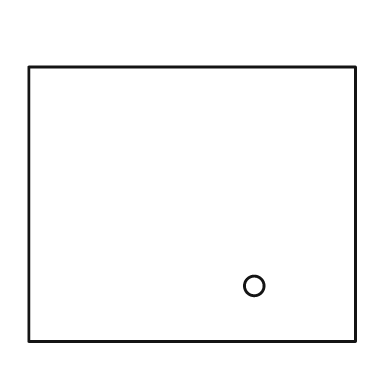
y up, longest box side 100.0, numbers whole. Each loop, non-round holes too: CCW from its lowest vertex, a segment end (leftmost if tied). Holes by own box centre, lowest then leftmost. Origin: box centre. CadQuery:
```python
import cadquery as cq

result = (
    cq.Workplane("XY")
    .moveTo(-50.0, -42.0)
    .lineTo(50.0, -42.0)
    .lineTo(50.0, 42.0)
    .lineTo(-50.0, 42.0)
    .close()
    .moveTo(19.0, -25.0)
    .circle(3.0)
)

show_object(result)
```